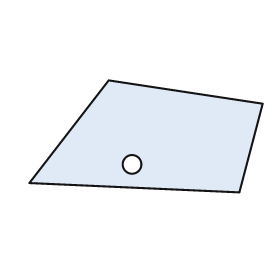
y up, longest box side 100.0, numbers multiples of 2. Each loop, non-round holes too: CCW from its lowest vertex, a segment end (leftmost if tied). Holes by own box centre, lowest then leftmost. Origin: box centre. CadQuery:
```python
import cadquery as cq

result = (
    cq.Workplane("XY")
    .moveTo(40.0, -24.0)
    .lineTo(50.0, 14.0)
    .lineTo(-16.0, 24.0)
    .lineTo(-50.0, -20.0)
    .close()
    .moveTo(-6.0, -12.0)
    .circle(4.0)
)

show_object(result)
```